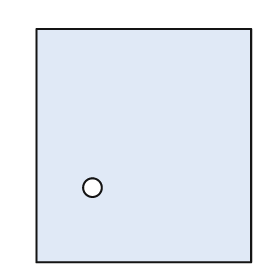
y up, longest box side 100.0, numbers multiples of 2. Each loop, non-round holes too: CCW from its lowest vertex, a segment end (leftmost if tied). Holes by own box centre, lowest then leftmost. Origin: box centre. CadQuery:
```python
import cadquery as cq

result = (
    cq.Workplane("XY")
    .moveTo(-46.0, -50.0)
    .lineTo(46.0, -50.0)
    .lineTo(46.0, 50.0)
    .lineTo(-46.0, 50.0)
    .close()
    .moveTo(-22.0, -18.0)
    .circle(4.0)
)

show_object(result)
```